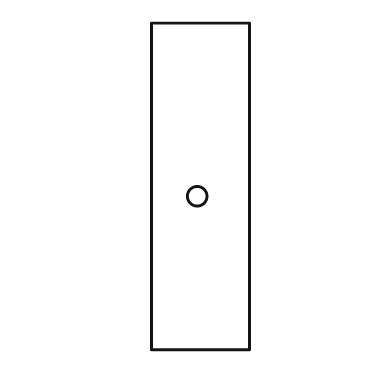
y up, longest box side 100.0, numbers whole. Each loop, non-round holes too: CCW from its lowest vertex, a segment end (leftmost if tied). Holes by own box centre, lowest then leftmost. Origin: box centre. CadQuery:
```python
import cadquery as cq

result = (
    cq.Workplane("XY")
    .moveTo(-15.0, -50.0)
    .lineTo(15.0, -50.0)
    .lineTo(15.0, 50.0)
    .lineTo(-15.0, 50.0)
    .close()
    .moveTo(-1.0, -3.0)
    .circle(3.0)
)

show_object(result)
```